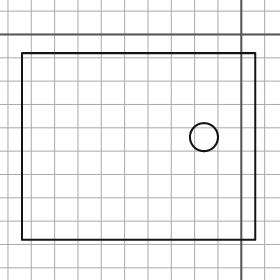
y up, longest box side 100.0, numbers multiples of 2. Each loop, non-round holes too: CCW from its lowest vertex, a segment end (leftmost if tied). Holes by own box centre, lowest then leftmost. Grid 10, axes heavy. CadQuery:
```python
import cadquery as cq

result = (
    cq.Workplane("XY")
    .moveTo(-94.0, -88.0)
    .lineTo(6.0, -88.0)
    .lineTo(6.0, -8.0)
    .lineTo(-94.0, -8.0)
    .close()
    .moveTo(-16.0, -44.0)
    .circle(6.0)
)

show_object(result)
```